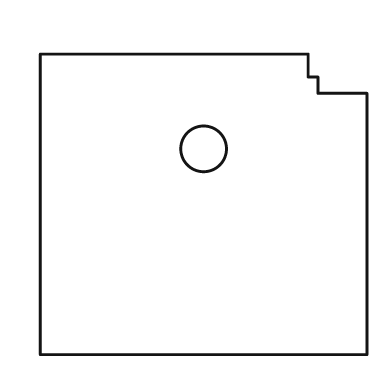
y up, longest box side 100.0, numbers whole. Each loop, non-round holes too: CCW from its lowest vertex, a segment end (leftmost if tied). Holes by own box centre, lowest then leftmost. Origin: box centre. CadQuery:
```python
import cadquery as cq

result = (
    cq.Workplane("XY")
    .moveTo(-50.0, -46.0)
    .lineTo(50.0, -46.0)
    .lineTo(50.0, 34.0)
    .lineTo(35.0, 34.0)
    .lineTo(35.0, 39.0)
    .lineTo(32.0, 39.0)
    .lineTo(32.0, 46.0)
    .lineTo(-50.0, 46.0)
    .close()
    .moveTo(0.0, 17.0)
    .circle(7.0)
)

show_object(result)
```